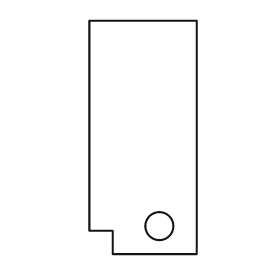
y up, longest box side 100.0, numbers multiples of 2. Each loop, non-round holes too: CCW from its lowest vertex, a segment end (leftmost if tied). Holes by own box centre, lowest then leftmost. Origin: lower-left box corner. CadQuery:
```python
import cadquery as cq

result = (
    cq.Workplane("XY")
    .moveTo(10.0, 0.0)
    .lineTo(46.0, 0.0)
    .lineTo(46.0, 100.0)
    .lineTo(0.0, 100.0)
    .lineTo(0.0, 10.0)
    .lineTo(10.0, 10.0)
    .close()
    .moveTo(30.0, 12.0)
    .circle(6.0)
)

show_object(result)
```